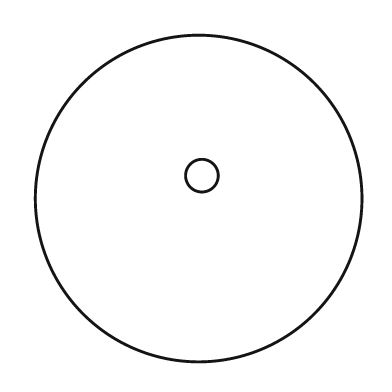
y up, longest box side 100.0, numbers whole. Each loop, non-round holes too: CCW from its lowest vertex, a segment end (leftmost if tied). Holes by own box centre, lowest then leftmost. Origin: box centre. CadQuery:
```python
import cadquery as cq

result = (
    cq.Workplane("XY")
    .moveTo(0.0, 0.0)
    .circle(50.0)
    .moveTo(1.0, 7.0)
    .circle(5.0)
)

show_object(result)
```